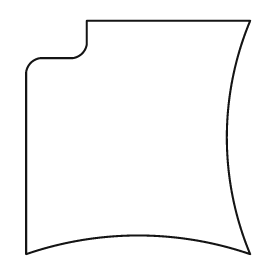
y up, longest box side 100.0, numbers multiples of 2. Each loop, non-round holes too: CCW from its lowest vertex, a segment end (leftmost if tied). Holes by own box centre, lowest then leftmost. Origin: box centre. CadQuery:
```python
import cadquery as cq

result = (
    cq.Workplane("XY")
    .moveTo(-48.0, -50.0)
    .threePointArc((0.0, -42.0), (48.0, -50.0))
    .threePointArc((38.0, 0.0), (48.0, 50.0))
    .lineTo(-22.0, 50.0)
    .lineTo(-22.0, 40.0)
    .threePointArc((-24.0, 36.0), (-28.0, 34.0))
    .lineTo(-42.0, 34.0)
    .threePointArc((-46.0, 32.0), (-48.0, 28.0))
    .close()
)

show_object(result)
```